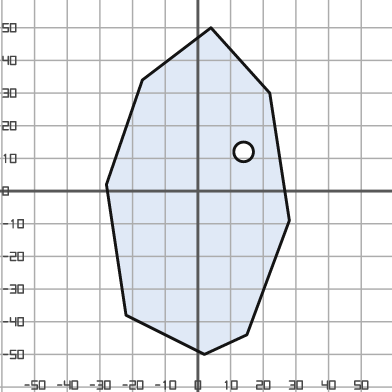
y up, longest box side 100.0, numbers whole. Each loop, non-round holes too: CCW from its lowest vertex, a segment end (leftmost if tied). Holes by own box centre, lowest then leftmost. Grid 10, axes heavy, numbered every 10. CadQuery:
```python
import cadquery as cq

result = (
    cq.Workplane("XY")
    .moveTo(2.0, -50.0)
    .lineTo(15.0, -44.0)
    .lineTo(28.0, -9.0)
    .lineTo(22.0, 30.0)
    .lineTo(4.0, 50.0)
    .lineTo(-17.0, 34.0)
    .lineTo(-28.0, 2.0)
    .lineTo(-22.0, -38.0)
    .close()
    .moveTo(14.0, 12.0)
    .circle(3.0)
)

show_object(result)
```